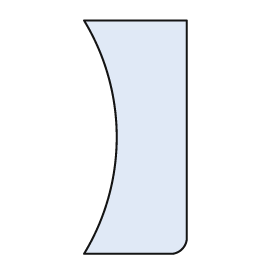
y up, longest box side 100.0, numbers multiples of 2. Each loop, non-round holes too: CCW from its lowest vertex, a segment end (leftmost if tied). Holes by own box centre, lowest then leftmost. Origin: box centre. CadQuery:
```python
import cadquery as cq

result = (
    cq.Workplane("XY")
    .moveTo(-22.0, -50.0)
    .lineTo(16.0, -50.0)
    .threePointArc((20.0, -48.0), (22.0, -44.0))
    .lineTo(22.0, 50.0)
    .lineTo(-22.0, 50.0)
    .threePointArc((-8.0, 0.0), (-22.0, -50.0))
    .close()
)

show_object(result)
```